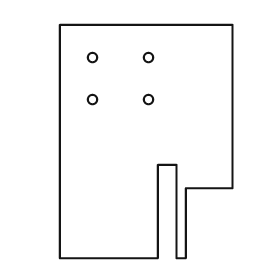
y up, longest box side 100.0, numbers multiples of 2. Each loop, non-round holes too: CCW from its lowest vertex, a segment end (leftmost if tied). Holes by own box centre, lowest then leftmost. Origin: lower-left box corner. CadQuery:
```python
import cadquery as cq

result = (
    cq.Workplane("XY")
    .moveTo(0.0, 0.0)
    .lineTo(42.0, 0.0)
    .lineTo(42.0, 40.0)
    .lineTo(50.0, 40.0)
    .lineTo(50.0, 0.0)
    .lineTo(54.0, 0.0)
    .lineTo(54.0, 30.0)
    .lineTo(74.0, 30.0)
    .lineTo(74.0, 100.0)
    .lineTo(0.0, 100.0)
    .close()
    .moveTo(14.0, 68.0)
    .circle(2.0)
    .moveTo(38.0, 68.0)
    .circle(2.0)
    .moveTo(14.0, 86.0)
    .circle(2.0)
    .moveTo(38.0, 86.0)
    .circle(2.0)
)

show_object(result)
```